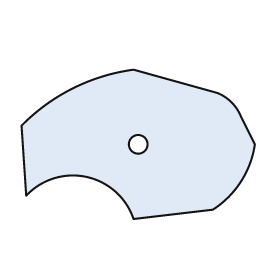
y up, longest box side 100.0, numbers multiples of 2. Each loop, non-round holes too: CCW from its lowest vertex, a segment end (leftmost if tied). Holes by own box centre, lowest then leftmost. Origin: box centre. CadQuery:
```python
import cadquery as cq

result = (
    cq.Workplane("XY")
    .moveTo(-2.0, -32.0)
    .lineTo(32.0, -28.0)
    .threePointArc((44.0, -16.0), (50.0, 0.0))
    .lineTo(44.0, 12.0)
    .threePointArc((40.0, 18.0), (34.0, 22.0))
    .lineTo(-2.0, 32.0)
    .threePointArc((-28.0, 24.0), (-50.0, 8.0))
    .lineTo(-48.0, -22.0)
    .threePointArc((-22.0, -14.0), (-2.0, -32.0))
    .close()
    .moveTo(0.0, 0.0)
    .circle(4.0)
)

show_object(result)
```